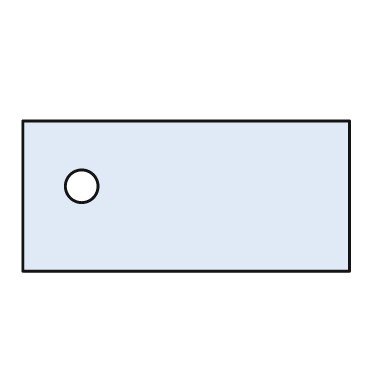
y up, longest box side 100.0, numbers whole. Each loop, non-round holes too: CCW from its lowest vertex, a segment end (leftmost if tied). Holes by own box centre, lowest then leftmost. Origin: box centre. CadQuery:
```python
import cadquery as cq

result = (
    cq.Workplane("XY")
    .moveTo(-50.0, -23.0)
    .lineTo(50.0, -23.0)
    .lineTo(50.0, 23.0)
    .lineTo(-50.0, 23.0)
    .close()
    .moveTo(-32.0, 3.0)
    .circle(5.0)
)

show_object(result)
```